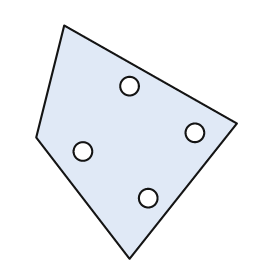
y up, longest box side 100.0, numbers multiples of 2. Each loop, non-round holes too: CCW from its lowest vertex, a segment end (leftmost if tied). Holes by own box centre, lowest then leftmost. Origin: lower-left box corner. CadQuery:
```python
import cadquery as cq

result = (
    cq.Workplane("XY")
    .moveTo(40.0, 0.0)
    .lineTo(86.0, 58.0)
    .lineTo(12.0, 100.0)
    .lineTo(0.0, 52.0)
    .close()
    .moveTo(48.0, 26.0)
    .circle(4.0)
    .moveTo(20.0, 46.0)
    .circle(4.0)
    .moveTo(68.0, 54.0)
    .circle(4.0)
    .moveTo(40.0, 74.0)
    .circle(4.0)
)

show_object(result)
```